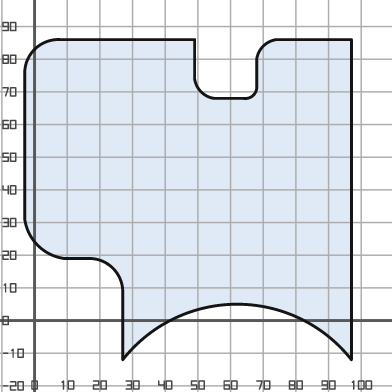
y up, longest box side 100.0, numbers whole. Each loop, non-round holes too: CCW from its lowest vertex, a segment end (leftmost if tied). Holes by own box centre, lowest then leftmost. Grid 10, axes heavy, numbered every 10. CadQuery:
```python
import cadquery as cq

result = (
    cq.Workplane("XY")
    .moveTo(27.0, -12.0)
    .threePointArc((62.0, 5.0), (97.0, -12.0))
    .lineTo(97.0, 86.0)
    .lineTo(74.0, 86.0)
    .threePointArc((70.0, 84.0), (68.0, 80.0))
    .lineTo(68.0, 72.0)
    .threePointArc((67.0, 69.0), (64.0, 68.0))
    .lineTo(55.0, 68.0)
    .threePointArc((51.0, 70.0), (49.0, 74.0))
    .lineTo(49.0, 86.0)
    .lineTo(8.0, 86.0)
    .threePointArc((0.0, 83.0), (-3.0, 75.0))
    .lineTo(-3.0, 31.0)
    .threePointArc((1.0, 23.0), (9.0, 19.0))
    .lineTo(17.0, 19.0)
    .threePointArc((24.0, 16.0), (27.0, 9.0))
    .close()
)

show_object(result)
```